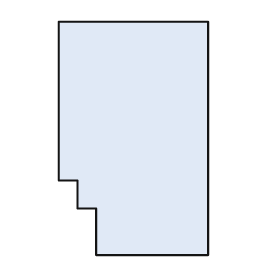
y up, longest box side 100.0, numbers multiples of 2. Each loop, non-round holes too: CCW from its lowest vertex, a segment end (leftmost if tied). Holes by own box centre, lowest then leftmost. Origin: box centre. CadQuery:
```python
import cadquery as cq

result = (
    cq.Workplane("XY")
    .moveTo(-16.0, -50.0)
    .lineTo(32.0, -50.0)
    .lineTo(32.0, 50.0)
    .lineTo(-32.0, 50.0)
    .lineTo(-32.0, -18.0)
    .lineTo(-24.0, -18.0)
    .lineTo(-24.0, -30.0)
    .lineTo(-16.0, -30.0)
    .close()
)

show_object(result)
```